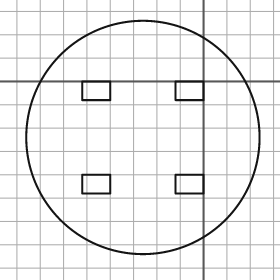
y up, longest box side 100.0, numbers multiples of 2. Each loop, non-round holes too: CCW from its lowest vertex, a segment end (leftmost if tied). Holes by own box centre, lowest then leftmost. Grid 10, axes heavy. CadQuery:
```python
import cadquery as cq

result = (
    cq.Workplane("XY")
    .moveTo(-26.0, -24.0)
    .circle(50.0)
    .moveTo(-52.0, -48.0)
    .lineTo(-40.0, -48.0)
    .lineTo(-40.0, -40.0)
    .lineTo(-52.0, -40.0)
    .close()
    .moveTo(-12.0, -48.0)
    .lineTo(0.0, -48.0)
    .lineTo(0.0, -40.0)
    .lineTo(-12.0, -40.0)
    .close()
    .moveTo(-52.0, -8.0)
    .lineTo(-40.0, -8.0)
    .lineTo(-40.0, 0.0)
    .lineTo(-52.0, 0.0)
    .close()
    .moveTo(-12.0, -8.0)
    .lineTo(0.0, -8.0)
    .lineTo(0.0, 0.0)
    .lineTo(-12.0, 0.0)
    .close()
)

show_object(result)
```